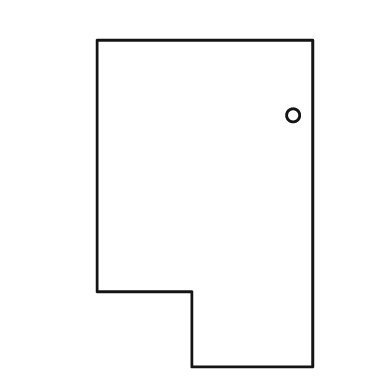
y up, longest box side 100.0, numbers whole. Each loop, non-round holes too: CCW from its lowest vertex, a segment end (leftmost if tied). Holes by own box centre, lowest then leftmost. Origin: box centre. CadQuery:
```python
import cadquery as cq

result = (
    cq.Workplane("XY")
    .moveTo(-4.0, -50.0)
    .lineTo(33.0, -50.0)
    .lineTo(33.0, 50.0)
    .lineTo(-33.0, 50.0)
    .lineTo(-33.0, -27.0)
    .lineTo(-4.0, -27.0)
    .close()
    .moveTo(27.0, 27.0)
    .circle(2.0)
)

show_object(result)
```